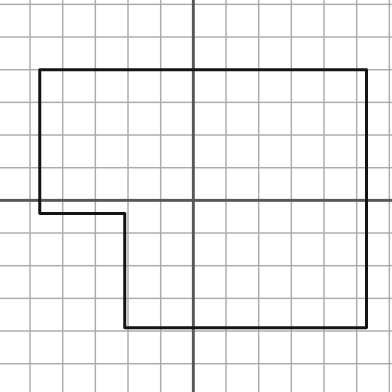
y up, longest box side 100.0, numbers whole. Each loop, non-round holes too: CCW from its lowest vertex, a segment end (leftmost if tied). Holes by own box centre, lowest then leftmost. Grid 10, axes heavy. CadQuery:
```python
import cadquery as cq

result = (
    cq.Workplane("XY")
    .moveTo(-21.0, -39.0)
    .lineTo(53.0, -39.0)
    .lineTo(53.0, 40.0)
    .lineTo(-47.0, 40.0)
    .lineTo(-47.0, -4.0)
    .lineTo(-21.0, -4.0)
    .close()
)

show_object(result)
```